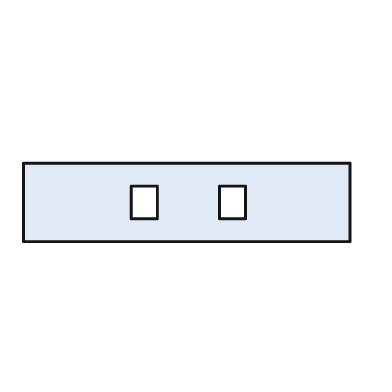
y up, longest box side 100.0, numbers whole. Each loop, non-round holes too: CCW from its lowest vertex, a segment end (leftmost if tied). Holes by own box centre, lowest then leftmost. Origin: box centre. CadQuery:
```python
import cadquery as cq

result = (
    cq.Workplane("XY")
    .moveTo(-50.0, -12.0)
    .lineTo(50.0, -12.0)
    .lineTo(50.0, 12.0)
    .lineTo(-50.0, 12.0)
    .close()
    .moveTo(-17.0, -5.0)
    .lineTo(-9.0, -5.0)
    .lineTo(-9.0, 5.0)
    .lineTo(-17.0, 5.0)
    .close()
    .moveTo(10.0, -5.0)
    .lineTo(18.0, -5.0)
    .lineTo(18.0, 5.0)
    .lineTo(10.0, 5.0)
    .close()
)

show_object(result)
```